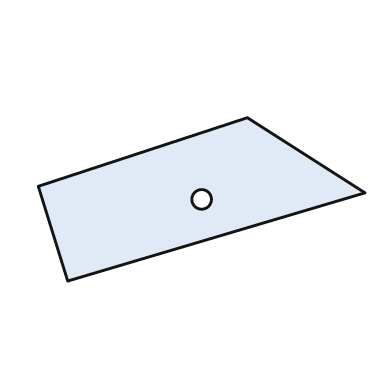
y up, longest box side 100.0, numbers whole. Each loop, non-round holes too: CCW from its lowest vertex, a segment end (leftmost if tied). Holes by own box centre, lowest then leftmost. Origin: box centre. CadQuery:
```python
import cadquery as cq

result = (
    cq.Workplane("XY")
    .moveTo(-41.0, -25.0)
    .lineTo(50.0, 2.0)
    .lineTo(14.0, 25.0)
    .lineTo(-50.0, 4.0)
    .close()
    .moveTo(0.0, 0.0)
    .circle(3.0)
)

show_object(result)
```